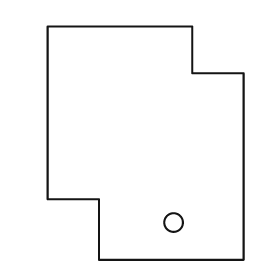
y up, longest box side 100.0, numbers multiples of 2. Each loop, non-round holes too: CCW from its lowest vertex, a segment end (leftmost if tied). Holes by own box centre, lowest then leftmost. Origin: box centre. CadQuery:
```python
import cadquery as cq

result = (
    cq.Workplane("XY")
    .moveTo(-20.0, -50.0)
    .lineTo(42.0, -50.0)
    .lineTo(42.0, 30.0)
    .lineTo(20.0, 30.0)
    .lineTo(20.0, 50.0)
    .lineTo(-42.0, 50.0)
    .lineTo(-42.0, -24.0)
    .lineTo(-20.0, -24.0)
    .close()
    .moveTo(12.0, -34.0)
    .circle(4.0)
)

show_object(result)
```